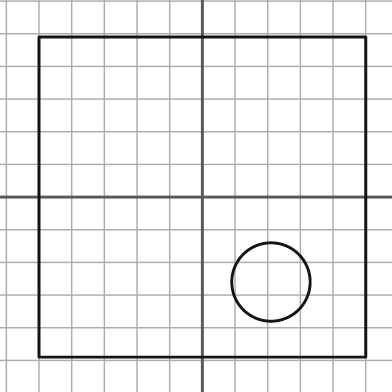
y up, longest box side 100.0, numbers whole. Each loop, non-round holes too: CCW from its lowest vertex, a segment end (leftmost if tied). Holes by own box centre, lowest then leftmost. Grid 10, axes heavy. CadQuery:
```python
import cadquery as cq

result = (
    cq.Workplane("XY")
    .moveTo(-50.0, -49.0)
    .lineTo(50.0, -49.0)
    .lineTo(50.0, 49.0)
    .lineTo(-50.0, 49.0)
    .close()
    .moveTo(21.0, -26.0)
    .circle(12.0)
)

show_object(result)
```